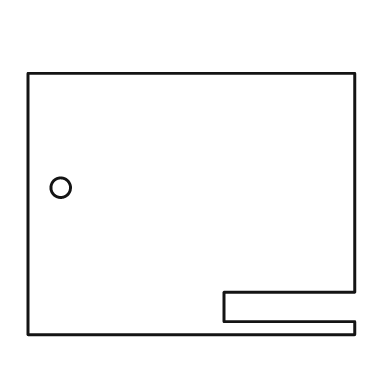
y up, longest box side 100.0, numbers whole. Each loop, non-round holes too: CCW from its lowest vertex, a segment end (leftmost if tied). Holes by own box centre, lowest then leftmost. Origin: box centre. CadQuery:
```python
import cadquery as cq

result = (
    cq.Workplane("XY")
    .moveTo(-50.0, -40.0)
    .lineTo(50.0, -40.0)
    .lineTo(50.0, -36.0)
    .lineTo(10.0, -36.0)
    .lineTo(10.0, -27.0)
    .lineTo(50.0, -27.0)
    .lineTo(50.0, 40.0)
    .lineTo(-50.0, 40.0)
    .close()
    .moveTo(-40.0, 5.0)
    .circle(3.0)
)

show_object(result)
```